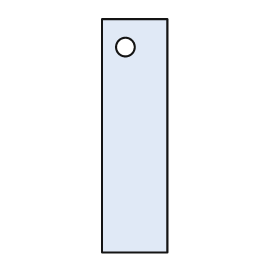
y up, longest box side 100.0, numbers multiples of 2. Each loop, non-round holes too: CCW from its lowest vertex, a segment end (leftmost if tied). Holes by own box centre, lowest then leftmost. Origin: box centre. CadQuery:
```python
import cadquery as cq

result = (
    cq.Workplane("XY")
    .moveTo(-14.0, -50.0)
    .lineTo(14.0, -50.0)
    .lineTo(14.0, 50.0)
    .lineTo(-14.0, 50.0)
    .close()
    .moveTo(-4.0, 38.0)
    .circle(4.0)
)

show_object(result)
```